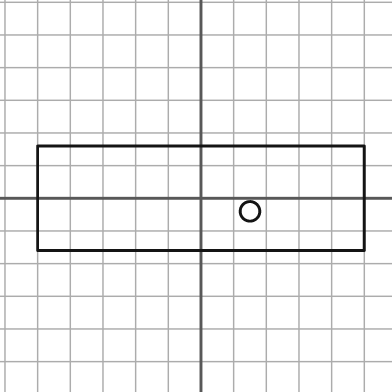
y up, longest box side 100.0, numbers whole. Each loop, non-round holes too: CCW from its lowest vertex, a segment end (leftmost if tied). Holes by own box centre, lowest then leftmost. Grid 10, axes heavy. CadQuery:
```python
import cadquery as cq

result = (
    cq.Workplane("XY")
    .moveTo(-50.0, -16.0)
    .lineTo(50.0, -16.0)
    .lineTo(50.0, 16.0)
    .lineTo(-50.0, 16.0)
    .close()
    .moveTo(15.0, -4.0)
    .circle(3.0)
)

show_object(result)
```